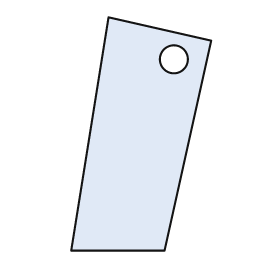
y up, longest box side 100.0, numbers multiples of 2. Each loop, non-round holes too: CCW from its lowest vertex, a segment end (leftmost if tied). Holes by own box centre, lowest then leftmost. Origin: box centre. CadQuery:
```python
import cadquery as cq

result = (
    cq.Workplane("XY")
    .moveTo(-30.0, -50.0)
    .lineTo(10.0, -50.0)
    .lineTo(30.0, 40.0)
    .lineTo(-14.0, 50.0)
    .close()
    .moveTo(14.0, 32.0)
    .circle(6.0)
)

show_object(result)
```